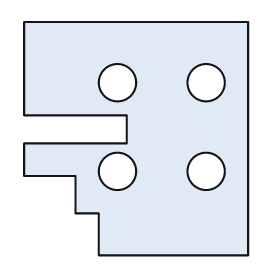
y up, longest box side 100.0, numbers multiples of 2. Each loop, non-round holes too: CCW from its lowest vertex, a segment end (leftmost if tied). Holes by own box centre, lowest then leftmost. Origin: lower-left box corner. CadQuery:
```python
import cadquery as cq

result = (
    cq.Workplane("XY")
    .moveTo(32.0, 0.0)
    .lineTo(96.0, 0.0)
    .lineTo(96.0, 100.0)
    .lineTo(0.0, 100.0)
    .lineTo(0.0, 60.0)
    .lineTo(44.0, 60.0)
    .lineTo(44.0, 48.0)
    .lineTo(0.0, 48.0)
    .lineTo(0.0, 34.0)
    .lineTo(22.0, 34.0)
    .lineTo(22.0, 18.0)
    .lineTo(32.0, 18.0)
    .close()
    .moveTo(40.0, 36.0)
    .circle(8.0)
    .moveTo(78.0, 36.0)
    .circle(8.0)
    .moveTo(40.0, 74.0)
    .circle(8.0)
    .moveTo(78.0, 74.0)
    .circle(8.0)
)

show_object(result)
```